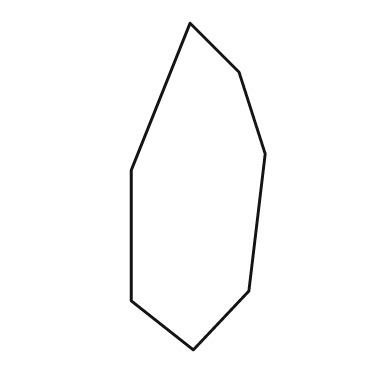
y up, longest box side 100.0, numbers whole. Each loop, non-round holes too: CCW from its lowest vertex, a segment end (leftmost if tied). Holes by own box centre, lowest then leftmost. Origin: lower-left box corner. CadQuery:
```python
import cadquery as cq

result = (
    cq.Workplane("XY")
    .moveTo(19.0, 0.0)
    .lineTo(36.0, 18.0)
    .lineTo(41.0, 60.0)
    .lineTo(33.0, 85.0)
    .lineTo(18.0, 100.0)
    .lineTo(0.0, 55.0)
    .lineTo(0.0, 15.0)
    .close()
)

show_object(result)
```